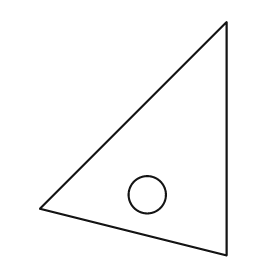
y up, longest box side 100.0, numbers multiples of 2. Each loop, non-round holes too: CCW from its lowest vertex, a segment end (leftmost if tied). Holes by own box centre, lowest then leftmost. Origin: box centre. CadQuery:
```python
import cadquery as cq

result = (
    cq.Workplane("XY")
    .moveTo(40.0, -50.0)
    .lineTo(40.0, 50.0)
    .lineTo(-40.0, -30.0)
    .close()
    .moveTo(6.0, -24.0)
    .circle(8.0)
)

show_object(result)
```